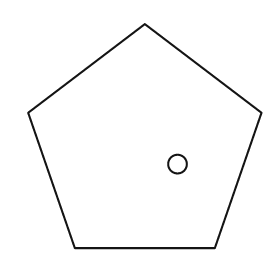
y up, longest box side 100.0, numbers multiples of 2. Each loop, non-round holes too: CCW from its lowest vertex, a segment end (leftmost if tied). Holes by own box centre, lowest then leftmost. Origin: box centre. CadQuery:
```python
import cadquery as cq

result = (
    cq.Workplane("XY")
    .moveTo(-30.0, -48.0)
    .lineTo(30.0, -48.0)
    .lineTo(50.0, 10.0)
    .lineTo(0.0, 48.0)
    .lineTo(-50.0, 10.0)
    .close()
    .moveTo(14.0, -12.0)
    .circle(4.0)
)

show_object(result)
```